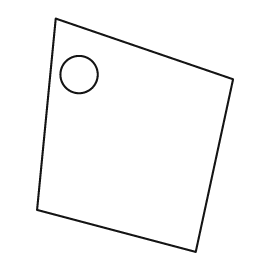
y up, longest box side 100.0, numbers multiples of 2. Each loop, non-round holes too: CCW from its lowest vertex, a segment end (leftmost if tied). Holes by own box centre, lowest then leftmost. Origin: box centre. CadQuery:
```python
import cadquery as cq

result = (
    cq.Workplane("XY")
    .moveTo(26.0, -50.0)
    .lineTo(42.0, 24.0)
    .lineTo(-34.0, 50.0)
    .lineTo(-42.0, -32.0)
    .close()
    .moveTo(-24.0, 26.0)
    .circle(8.0)
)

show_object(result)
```